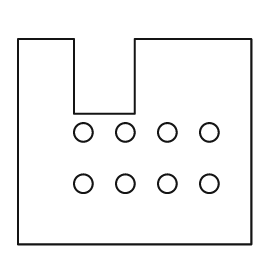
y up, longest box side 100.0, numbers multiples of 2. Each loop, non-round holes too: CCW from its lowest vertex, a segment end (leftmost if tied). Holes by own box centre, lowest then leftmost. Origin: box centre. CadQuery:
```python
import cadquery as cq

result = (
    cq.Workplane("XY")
    .moveTo(-50.0, -44.0)
    .lineTo(50.0, -44.0)
    .lineTo(50.0, 44.0)
    .lineTo(0.0, 44.0)
    .lineTo(0.0, 12.0)
    .lineTo(-26.0, 12.0)
    .lineTo(-26.0, 44.0)
    .lineTo(-50.0, 44.0)
    .close()
    .moveTo(-22.0, -18.0)
    .circle(4.0)
    .moveTo(-4.0, -18.0)
    .circle(4.0)
    .moveTo(14.0, -18.0)
    .circle(4.0)
    .moveTo(32.0, -18.0)
    .circle(4.0)
    .moveTo(-22.0, 4.0)
    .circle(4.0)
    .moveTo(-4.0, 4.0)
    .circle(4.0)
    .moveTo(14.0, 4.0)
    .circle(4.0)
    .moveTo(32.0, 4.0)
    .circle(4.0)
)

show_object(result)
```